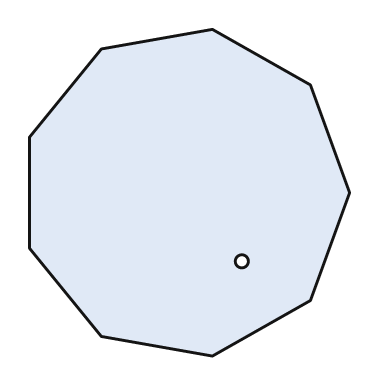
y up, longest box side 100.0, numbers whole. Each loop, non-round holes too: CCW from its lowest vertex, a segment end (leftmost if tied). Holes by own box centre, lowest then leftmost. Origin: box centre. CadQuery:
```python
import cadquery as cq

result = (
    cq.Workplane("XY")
    .moveTo(7.0, -50.0)
    .lineTo(37.0, -33.0)
    .lineTo(49.0, 0.0)
    .lineTo(37.0, 33.0)
    .lineTo(7.0, 50.0)
    .lineTo(-27.0, 44.0)
    .lineTo(-49.0, 17.0)
    .lineTo(-49.0, -17.0)
    .lineTo(-27.0, -44.0)
    .close()
    .moveTo(16.0, -21.0)
    .circle(2.0)
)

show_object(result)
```